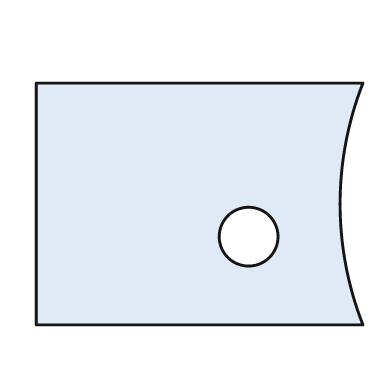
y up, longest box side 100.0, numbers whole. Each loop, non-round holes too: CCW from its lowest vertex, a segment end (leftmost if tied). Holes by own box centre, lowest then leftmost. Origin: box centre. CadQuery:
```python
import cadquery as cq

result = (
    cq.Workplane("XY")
    .moveTo(-50.0, -37.0)
    .lineTo(50.0, -37.0)
    .threePointArc((43.0, 0.0), (50.0, 37.0))
    .lineTo(-50.0, 37.0)
    .close()
    .moveTo(15.0, -10.0)
    .circle(9.0)
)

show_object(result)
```